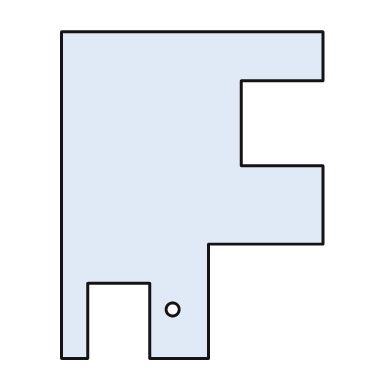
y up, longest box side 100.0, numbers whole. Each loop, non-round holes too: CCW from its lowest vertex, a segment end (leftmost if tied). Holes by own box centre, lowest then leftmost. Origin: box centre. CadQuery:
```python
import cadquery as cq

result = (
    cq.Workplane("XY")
    .moveTo(-40.0, -50.0)
    .lineTo(-32.0, -50.0)
    .lineTo(-32.0, -27.0)
    .lineTo(-13.0, -27.0)
    .lineTo(-13.0, -50.0)
    .lineTo(5.0, -50.0)
    .lineTo(5.0, -15.0)
    .lineTo(40.0, -15.0)
    .lineTo(40.0, 9.0)
    .lineTo(15.0, 9.0)
    .lineTo(15.0, 35.0)
    .lineTo(40.0, 35.0)
    .lineTo(40.0, 50.0)
    .lineTo(-40.0, 50.0)
    .close()
    .moveTo(-6.0, -35.0)
    .circle(2.0)
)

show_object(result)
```